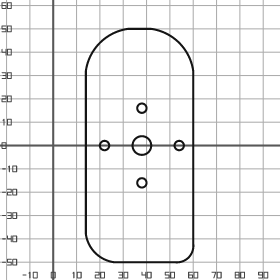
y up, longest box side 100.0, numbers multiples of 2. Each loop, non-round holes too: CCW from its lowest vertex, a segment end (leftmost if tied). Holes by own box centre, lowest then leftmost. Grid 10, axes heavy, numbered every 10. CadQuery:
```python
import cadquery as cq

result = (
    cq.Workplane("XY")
    .moveTo(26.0, -50.0)
    .lineTo(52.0, -50.0)
    .threePointArc((58.0, -48.0), (60.0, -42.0))
    .lineTo(60.0, 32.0)
    .threePointArc((54.0, 44.0), (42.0, 50.0))
    .lineTo(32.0, 50.0)
    .threePointArc((20.0, 44.0), (14.0, 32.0))
    .lineTo(14.0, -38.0)
    .threePointArc((18.0, -46.0), (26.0, -50.0))
    .close()
    .moveTo(38.0, -16.0)
    .circle(2.0)
    .moveTo(22.0, 0.0)
    .circle(2.0)
    .moveTo(38.0, 0.0)
    .circle(4.0)
    .moveTo(54.0, 0.0)
    .circle(2.0)
    .moveTo(38.0, 16.0)
    .circle(2.0)
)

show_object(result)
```